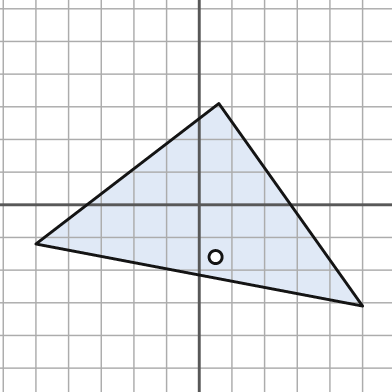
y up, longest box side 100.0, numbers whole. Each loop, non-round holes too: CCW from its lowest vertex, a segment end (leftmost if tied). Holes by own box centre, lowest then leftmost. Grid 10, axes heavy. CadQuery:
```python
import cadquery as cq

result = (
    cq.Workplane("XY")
    .moveTo(50.0, -31.0)
    .lineTo(6.0, 31.0)
    .lineTo(-50.0, -12.0)
    .close()
    .moveTo(5.0, -16.0)
    .circle(2.0)
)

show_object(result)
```